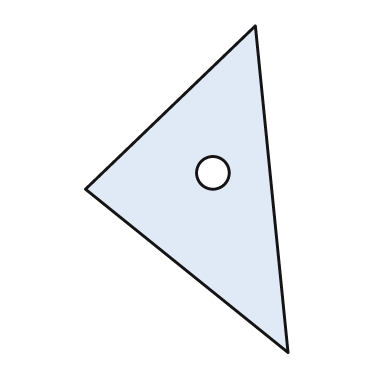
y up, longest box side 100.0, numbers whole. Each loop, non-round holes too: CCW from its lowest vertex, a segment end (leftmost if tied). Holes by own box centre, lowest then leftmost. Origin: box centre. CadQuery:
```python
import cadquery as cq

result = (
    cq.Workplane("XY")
    .moveTo(31.0, -50.0)
    .lineTo(21.0, 50.0)
    .lineTo(-31.0, 0.0)
    .close()
    .moveTo(8.0, 5.0)
    .circle(5.0)
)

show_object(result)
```